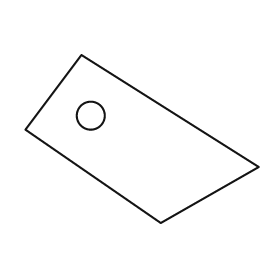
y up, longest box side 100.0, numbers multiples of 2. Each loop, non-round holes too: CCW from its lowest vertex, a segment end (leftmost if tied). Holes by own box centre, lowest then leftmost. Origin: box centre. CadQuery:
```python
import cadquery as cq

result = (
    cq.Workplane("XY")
    .moveTo(8.0, -36.0)
    .lineTo(50.0, -12.0)
    .lineTo(-26.0, 36.0)
    .lineTo(-50.0, 4.0)
    .close()
    .moveTo(-22.0, 10.0)
    .circle(6.0)
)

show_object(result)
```